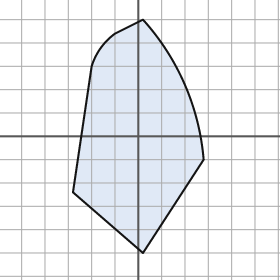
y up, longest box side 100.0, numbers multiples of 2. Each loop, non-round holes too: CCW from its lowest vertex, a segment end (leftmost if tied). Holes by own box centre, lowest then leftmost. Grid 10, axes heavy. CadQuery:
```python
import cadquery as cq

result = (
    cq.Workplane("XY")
    .moveTo(2.0, -50.0)
    .lineTo(28.0, -10.0)
    .threePointArc((20.0, 22.0), (2.0, 50.0))
    .lineTo(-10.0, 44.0)
    .threePointArc((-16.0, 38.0), (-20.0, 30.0))
    .lineTo(-28.0, -24.0)
    .close()
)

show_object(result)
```